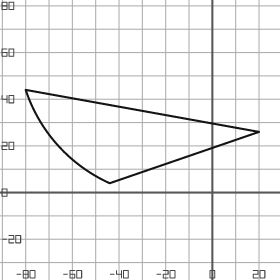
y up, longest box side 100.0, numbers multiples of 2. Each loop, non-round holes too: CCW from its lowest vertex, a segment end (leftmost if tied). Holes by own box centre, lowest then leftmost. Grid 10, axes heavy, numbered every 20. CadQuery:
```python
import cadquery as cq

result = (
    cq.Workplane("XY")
    .moveTo(-44.0, 4.0)
    .lineTo(20.0, 26.0)
    .lineTo(-80.0, 44.0)
    .threePointArc((-66.0, 20.0), (-44.0, 4.0))
    .close()
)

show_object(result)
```